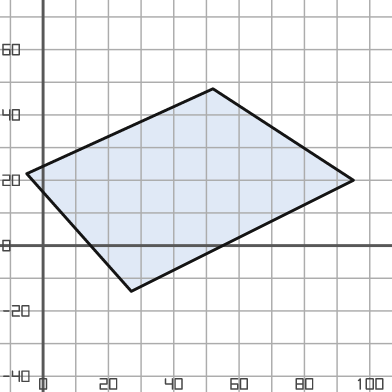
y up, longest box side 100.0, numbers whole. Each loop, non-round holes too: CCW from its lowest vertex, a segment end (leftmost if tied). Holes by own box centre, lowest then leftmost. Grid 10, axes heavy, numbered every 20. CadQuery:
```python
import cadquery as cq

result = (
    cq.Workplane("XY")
    .moveTo(27.0, -14.0)
    .lineTo(95.0, 20.0)
    .lineTo(52.0, 48.0)
    .lineTo(-5.0, 22.0)
    .close()
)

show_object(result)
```